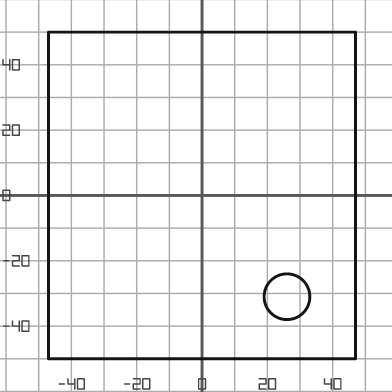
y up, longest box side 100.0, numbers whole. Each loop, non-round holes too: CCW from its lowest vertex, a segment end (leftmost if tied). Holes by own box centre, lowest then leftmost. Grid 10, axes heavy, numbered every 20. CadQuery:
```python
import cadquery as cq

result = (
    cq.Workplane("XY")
    .moveTo(-47.0, -50.0)
    .lineTo(47.0, -50.0)
    .lineTo(47.0, 50.0)
    .lineTo(-47.0, 50.0)
    .close()
    .moveTo(26.0, -31.0)
    .circle(7.0)
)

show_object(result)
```